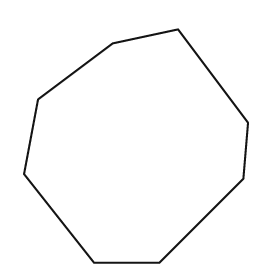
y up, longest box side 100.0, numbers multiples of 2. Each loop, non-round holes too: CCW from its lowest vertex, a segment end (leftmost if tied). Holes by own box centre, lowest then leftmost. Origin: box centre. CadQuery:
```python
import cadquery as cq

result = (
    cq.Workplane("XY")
    .moveTo(-18.0, -50.0)
    .lineTo(10.0, -50.0)
    .lineTo(46.0, -14.0)
    .lineTo(48.0, 10.0)
    .lineTo(18.0, 50.0)
    .lineTo(-10.0, 44.0)
    .lineTo(-42.0, 20.0)
    .lineTo(-48.0, -12.0)
    .close()
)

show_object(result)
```